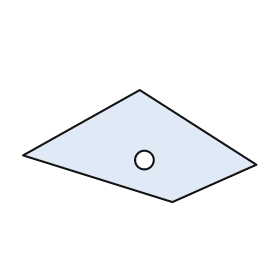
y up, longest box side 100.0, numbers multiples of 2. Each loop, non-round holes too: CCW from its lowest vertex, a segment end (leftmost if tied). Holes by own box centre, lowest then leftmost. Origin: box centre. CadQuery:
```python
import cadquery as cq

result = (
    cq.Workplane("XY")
    .moveTo(14.0, -24.0)
    .lineTo(50.0, -8.0)
    .lineTo(0.0, 24.0)
    .lineTo(-50.0, -4.0)
    .close()
    .moveTo(2.0, -6.0)
    .circle(4.0)
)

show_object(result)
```